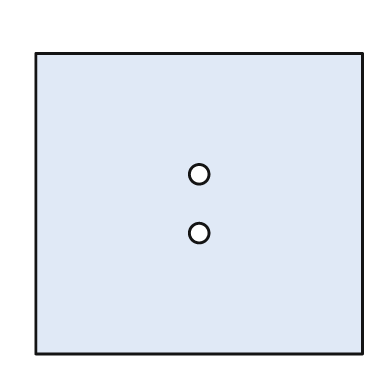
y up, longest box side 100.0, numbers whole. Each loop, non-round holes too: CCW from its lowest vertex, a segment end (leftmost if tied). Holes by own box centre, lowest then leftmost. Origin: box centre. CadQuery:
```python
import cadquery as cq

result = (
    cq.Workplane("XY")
    .moveTo(-50.0, -46.0)
    .lineTo(50.0, -46.0)
    .lineTo(50.0, 46.0)
    .lineTo(-50.0, 46.0)
    .close()
    .moveTo(0.0, -9.0)
    .circle(3.0)
    .moveTo(0.0, 9.0)
    .circle(3.0)
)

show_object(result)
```